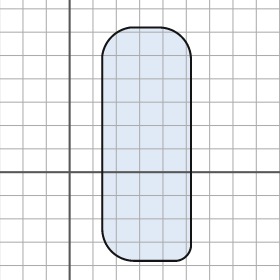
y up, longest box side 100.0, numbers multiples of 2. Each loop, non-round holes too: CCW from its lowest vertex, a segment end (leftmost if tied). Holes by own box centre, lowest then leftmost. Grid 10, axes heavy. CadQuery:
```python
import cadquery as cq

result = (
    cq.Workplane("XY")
    .moveTo(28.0, -38.0)
    .lineTo(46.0, -38.0)
    .threePointArc((50.0, -36.0), (52.0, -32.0))
    .lineTo(52.0, 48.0)
    .threePointArc((48.0, 58.0), (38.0, 62.0))
    .lineTo(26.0, 62.0)
    .threePointArc((18.0, 58.0), (14.0, 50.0))
    .lineTo(14.0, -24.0)
    .threePointArc((18.0, -34.0), (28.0, -38.0))
    .close()
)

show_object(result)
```